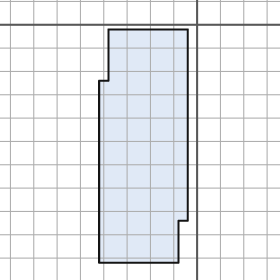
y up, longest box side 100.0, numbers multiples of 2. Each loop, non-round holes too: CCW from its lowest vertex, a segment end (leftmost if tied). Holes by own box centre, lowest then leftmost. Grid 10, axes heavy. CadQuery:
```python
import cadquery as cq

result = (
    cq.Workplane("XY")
    .moveTo(-42.0, -102.0)
    .lineTo(-8.0, -102.0)
    .lineTo(-8.0, -84.0)
    .lineTo(-4.0, -84.0)
    .lineTo(-4.0, -2.0)
    .lineTo(-38.0, -2.0)
    .lineTo(-38.0, -24.0)
    .lineTo(-42.0, -24.0)
    .close()
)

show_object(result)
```